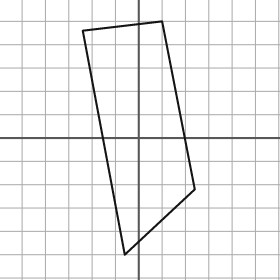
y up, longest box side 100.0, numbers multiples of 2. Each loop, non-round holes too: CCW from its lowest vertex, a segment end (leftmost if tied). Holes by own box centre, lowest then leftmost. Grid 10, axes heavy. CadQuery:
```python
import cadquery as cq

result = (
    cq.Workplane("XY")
    .moveTo(-6.0, -50.0)
    .lineTo(24.0, -22.0)
    .lineTo(10.0, 50.0)
    .lineTo(-24.0, 46.0)
    .close()
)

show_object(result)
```